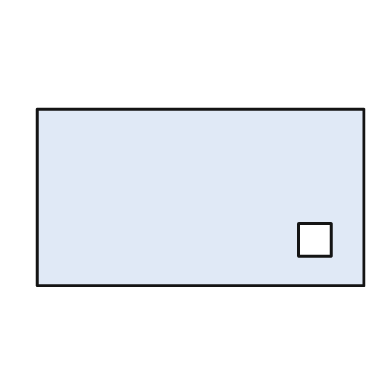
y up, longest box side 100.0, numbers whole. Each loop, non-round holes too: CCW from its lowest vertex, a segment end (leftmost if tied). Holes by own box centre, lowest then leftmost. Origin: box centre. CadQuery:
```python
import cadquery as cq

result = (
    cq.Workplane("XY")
    .moveTo(-50.0, -27.0)
    .lineTo(50.0, -27.0)
    .lineTo(50.0, 27.0)
    .lineTo(-50.0, 27.0)
    .close()
    .moveTo(30.0, -18.0)
    .lineTo(40.0, -18.0)
    .lineTo(40.0, -8.0)
    .lineTo(30.0, -8.0)
    .close()
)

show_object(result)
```